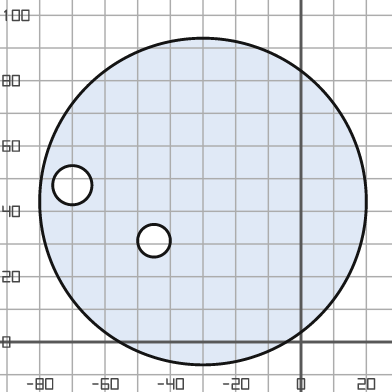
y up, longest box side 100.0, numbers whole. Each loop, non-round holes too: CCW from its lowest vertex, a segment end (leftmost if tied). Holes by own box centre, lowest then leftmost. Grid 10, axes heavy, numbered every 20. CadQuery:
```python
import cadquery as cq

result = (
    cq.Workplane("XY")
    .moveTo(-30.0, 43.0)
    .circle(50.0)
    .moveTo(-45.0, 31.0)
    .circle(5.0)
    .moveTo(-70.0, 48.0)
    .circle(6.0)
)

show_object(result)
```